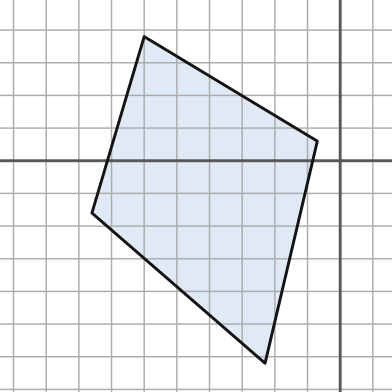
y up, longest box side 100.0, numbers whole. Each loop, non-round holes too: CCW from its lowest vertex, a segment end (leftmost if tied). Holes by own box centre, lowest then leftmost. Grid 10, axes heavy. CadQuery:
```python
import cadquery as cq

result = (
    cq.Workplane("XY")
    .moveTo(-23.0, -62.0)
    .lineTo(-7.0, 6.0)
    .lineTo(-60.0, 38.0)
    .lineTo(-76.0, -16.0)
    .close()
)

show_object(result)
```